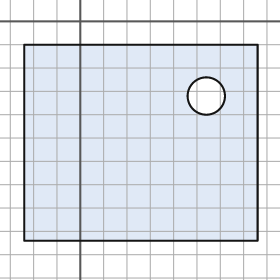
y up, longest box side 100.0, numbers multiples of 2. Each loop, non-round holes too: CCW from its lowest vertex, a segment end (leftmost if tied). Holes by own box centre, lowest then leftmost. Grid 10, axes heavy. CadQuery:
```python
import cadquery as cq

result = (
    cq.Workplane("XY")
    .moveTo(-24.0, -94.0)
    .lineTo(76.0, -94.0)
    .lineTo(76.0, -10.0)
    .lineTo(-24.0, -10.0)
    .close()
    .moveTo(54.0, -32.0)
    .circle(8.0)
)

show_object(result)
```